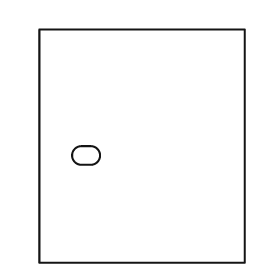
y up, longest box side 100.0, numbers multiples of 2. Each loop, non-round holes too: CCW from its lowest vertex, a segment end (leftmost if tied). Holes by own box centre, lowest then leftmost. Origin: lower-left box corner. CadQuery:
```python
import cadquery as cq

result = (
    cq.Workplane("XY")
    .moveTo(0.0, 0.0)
    .lineTo(88.0, 0.0)
    .lineTo(88.0, 100.0)
    .lineTo(0.0, 100.0)
    .close()
    .moveTo(18.0, 42.0)
    .lineTo(22.0, 42.0)
    .threePointArc((26.0, 46.0), (22.0, 50.0))
    .lineTo(18.0, 50.0)
    .threePointArc((14.0, 46.0), (18.0, 42.0))
    .close()
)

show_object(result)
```